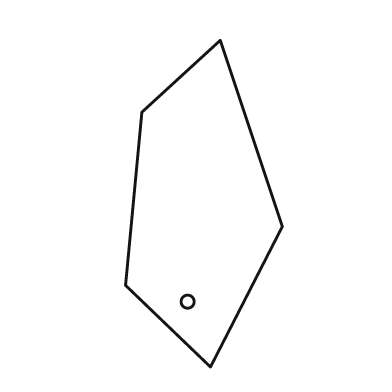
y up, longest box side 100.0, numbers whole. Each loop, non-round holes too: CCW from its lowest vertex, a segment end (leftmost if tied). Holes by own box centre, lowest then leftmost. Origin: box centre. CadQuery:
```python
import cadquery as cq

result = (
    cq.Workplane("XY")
    .moveTo(2.0, -50.0)
    .lineTo(24.0, -7.0)
    .lineTo(5.0, 50.0)
    .lineTo(-19.0, 28.0)
    .lineTo(-24.0, -25.0)
    .close()
    .moveTo(-5.0, -30.0)
    .circle(2.0)
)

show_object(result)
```